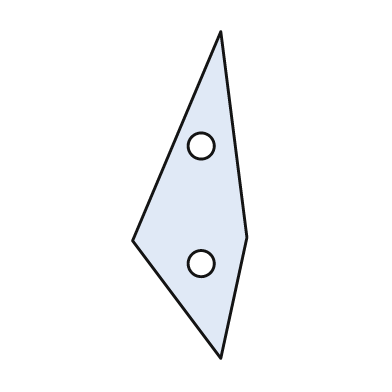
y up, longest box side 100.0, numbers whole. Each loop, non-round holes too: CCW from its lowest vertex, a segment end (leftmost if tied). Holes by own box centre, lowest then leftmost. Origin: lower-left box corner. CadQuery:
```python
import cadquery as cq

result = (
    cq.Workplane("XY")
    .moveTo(27.0, 0.0)
    .lineTo(35.0, 37.0)
    .lineTo(27.0, 100.0)
    .lineTo(0.0, 36.0)
    .close()
    .moveTo(21.0, 29.0)
    .circle(4.0)
    .moveTo(21.0, 65.0)
    .circle(4.0)
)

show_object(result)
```